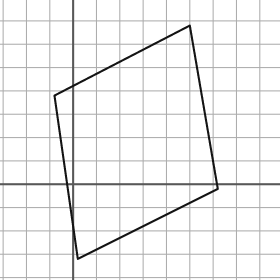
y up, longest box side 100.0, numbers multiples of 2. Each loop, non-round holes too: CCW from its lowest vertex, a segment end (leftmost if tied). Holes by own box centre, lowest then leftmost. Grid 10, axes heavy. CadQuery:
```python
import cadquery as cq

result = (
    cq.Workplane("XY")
    .moveTo(2.0, -32.0)
    .lineTo(62.0, -2.0)
    .lineTo(50.0, 68.0)
    .lineTo(-8.0, 38.0)
    .close()
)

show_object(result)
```